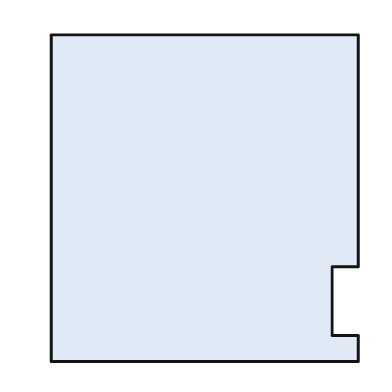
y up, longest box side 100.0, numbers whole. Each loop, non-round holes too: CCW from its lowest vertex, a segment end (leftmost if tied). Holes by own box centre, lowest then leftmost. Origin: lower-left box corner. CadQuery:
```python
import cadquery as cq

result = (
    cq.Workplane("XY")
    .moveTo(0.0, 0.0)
    .lineTo(94.0, 0.0)
    .lineTo(94.0, 8.0)
    .lineTo(86.0, 8.0)
    .lineTo(86.0, 29.0)
    .lineTo(94.0, 29.0)
    .lineTo(94.0, 100.0)
    .lineTo(0.0, 100.0)
    .close()
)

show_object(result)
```